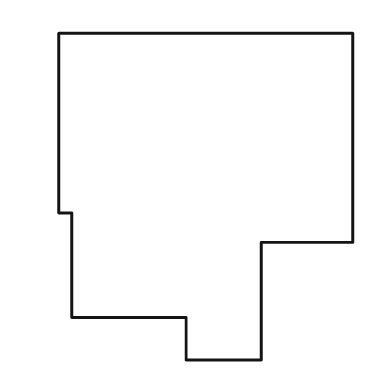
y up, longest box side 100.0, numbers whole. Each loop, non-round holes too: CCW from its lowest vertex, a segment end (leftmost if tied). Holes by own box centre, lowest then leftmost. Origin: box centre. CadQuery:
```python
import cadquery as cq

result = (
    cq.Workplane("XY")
    .moveTo(-6.0, -50.0)
    .lineTo(17.0, -50.0)
    .lineTo(17.0, -14.0)
    .lineTo(45.0, -14.0)
    .lineTo(45.0, 50.0)
    .lineTo(-45.0, 50.0)
    .lineTo(-45.0, -5.0)
    .lineTo(-41.0, -5.0)
    .lineTo(-41.0, -37.0)
    .lineTo(-6.0, -37.0)
    .close()
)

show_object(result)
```